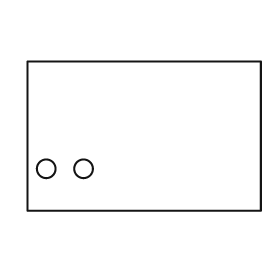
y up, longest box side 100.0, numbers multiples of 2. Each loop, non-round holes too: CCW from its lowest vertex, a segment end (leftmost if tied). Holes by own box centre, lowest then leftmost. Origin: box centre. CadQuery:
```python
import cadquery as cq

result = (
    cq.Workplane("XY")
    .moveTo(-50.0, -32.0)
    .lineTo(50.0, -32.0)
    .lineTo(50.0, 32.0)
    .lineTo(-50.0, 32.0)
    .close()
    .moveTo(-42.0, -14.0)
    .circle(4.0)
    .moveTo(-26.0, -14.0)
    .circle(4.0)
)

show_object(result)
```